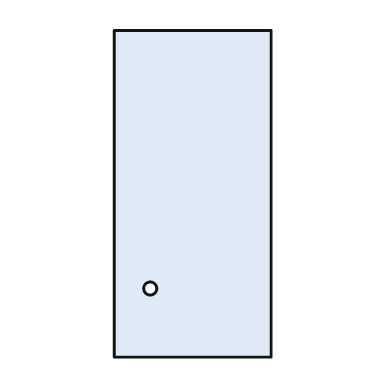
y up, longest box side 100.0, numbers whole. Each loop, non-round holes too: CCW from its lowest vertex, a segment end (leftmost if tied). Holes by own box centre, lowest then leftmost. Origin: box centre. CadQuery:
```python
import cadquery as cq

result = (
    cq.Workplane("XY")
    .moveTo(-24.0, -50.0)
    .lineTo(24.0, -50.0)
    .lineTo(24.0, 50.0)
    .lineTo(-24.0, 50.0)
    .close()
    .moveTo(-13.0, -29.0)
    .circle(2.0)
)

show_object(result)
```